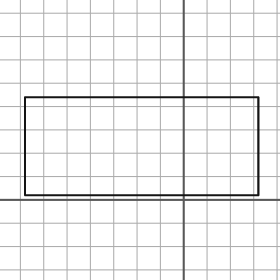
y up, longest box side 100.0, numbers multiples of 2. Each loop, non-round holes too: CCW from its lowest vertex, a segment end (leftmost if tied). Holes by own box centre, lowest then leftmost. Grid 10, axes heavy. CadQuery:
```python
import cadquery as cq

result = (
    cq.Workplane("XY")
    .moveTo(-68.0, 2.0)
    .lineTo(32.0, 2.0)
    .lineTo(32.0, 44.0)
    .lineTo(-68.0, 44.0)
    .close()
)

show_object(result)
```